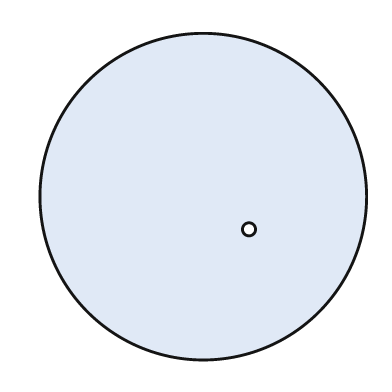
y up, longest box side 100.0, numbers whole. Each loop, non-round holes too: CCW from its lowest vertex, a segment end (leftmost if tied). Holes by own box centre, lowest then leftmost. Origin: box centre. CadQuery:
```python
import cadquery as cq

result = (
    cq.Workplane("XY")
    .moveTo(0.0, 0.0)
    .circle(50.0)
    .moveTo(14.0, -10.0)
    .circle(2.0)
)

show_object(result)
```